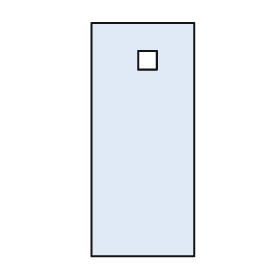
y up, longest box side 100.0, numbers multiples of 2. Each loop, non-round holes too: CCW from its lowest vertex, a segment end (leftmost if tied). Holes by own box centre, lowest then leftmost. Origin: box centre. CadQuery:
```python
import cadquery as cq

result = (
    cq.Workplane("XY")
    .moveTo(-22.0, -50.0)
    .lineTo(22.0, -50.0)
    .lineTo(22.0, 50.0)
    .lineTo(-22.0, 50.0)
    .close()
    .moveTo(-2.0, 30.0)
    .lineTo(6.0, 30.0)
    .lineTo(6.0, 38.0)
    .lineTo(-2.0, 38.0)
    .close()
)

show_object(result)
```